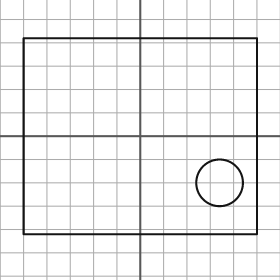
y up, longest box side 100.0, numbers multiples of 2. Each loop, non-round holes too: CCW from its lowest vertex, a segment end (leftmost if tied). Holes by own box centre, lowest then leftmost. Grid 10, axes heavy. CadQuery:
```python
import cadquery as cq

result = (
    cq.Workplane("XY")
    .moveTo(-50.0, -42.0)
    .lineTo(50.0, -42.0)
    .lineTo(50.0, 42.0)
    .lineTo(-50.0, 42.0)
    .close()
    .moveTo(34.0, -20.0)
    .circle(10.0)
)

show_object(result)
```